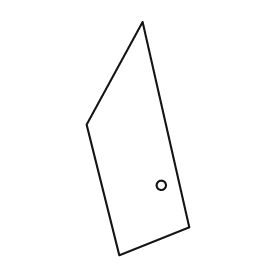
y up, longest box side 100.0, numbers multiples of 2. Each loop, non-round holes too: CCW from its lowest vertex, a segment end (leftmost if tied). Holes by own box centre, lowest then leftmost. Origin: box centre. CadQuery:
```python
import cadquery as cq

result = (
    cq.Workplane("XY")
    .moveTo(-8.0, -50.0)
    .lineTo(22.0, -38.0)
    .lineTo(2.0, 50.0)
    .lineTo(-22.0, 6.0)
    .close()
    .moveTo(10.0, -20.0)
    .circle(2.0)
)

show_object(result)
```